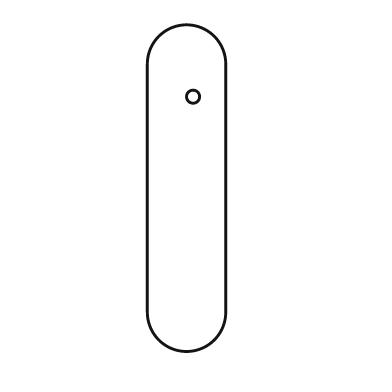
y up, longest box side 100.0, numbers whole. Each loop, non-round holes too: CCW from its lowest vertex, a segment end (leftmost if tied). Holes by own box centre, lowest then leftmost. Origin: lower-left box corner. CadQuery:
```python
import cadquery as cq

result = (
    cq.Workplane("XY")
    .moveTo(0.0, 12.0)
    .threePointArc((12.0, 0.0), (24.0, 12.0))
    .lineTo(24.0, 88.0)
    .threePointArc((12.0, 100.0), (0.0, 88.0))
    .close()
    .moveTo(14.0, 78.0)
    .circle(2.0)
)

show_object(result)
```